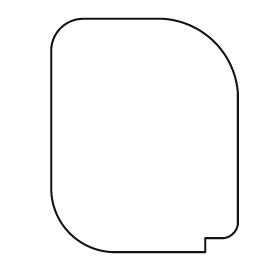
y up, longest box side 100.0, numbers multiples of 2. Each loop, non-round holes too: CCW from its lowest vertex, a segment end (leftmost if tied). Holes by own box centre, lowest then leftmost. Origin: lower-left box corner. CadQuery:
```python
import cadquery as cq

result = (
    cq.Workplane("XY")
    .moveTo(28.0, 0.0)
    .lineTo(66.0, 0.0)
    .lineTo(66.0, 6.0)
    .lineTo(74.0, 6.0)
    .threePointArc((78.0, 8.0), (80.0, 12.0))
    .lineTo(80.0, 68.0)
    .threePointArc((70.0, 90.0), (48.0, 100.0))
    .lineTo(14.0, 100.0)
    .threePointArc((4.0, 96.0), (0.0, 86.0))
    .lineTo(0.0, 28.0)
    .threePointArc((8.0, 8.0), (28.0, 0.0))
    .close()
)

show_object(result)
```